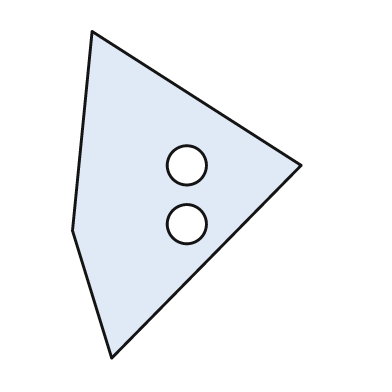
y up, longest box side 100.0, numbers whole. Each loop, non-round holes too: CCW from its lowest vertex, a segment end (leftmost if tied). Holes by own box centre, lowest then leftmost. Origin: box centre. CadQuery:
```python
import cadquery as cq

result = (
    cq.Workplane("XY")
    .moveTo(-23.0, -50.0)
    .lineTo(35.0, 9.0)
    .lineTo(-29.0, 50.0)
    .lineTo(-35.0, -11.0)
    .close()
    .moveTo(0.0, -9.0)
    .circle(6.0)
    .moveTo(0.0, 9.0)
    .circle(6.0)
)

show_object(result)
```